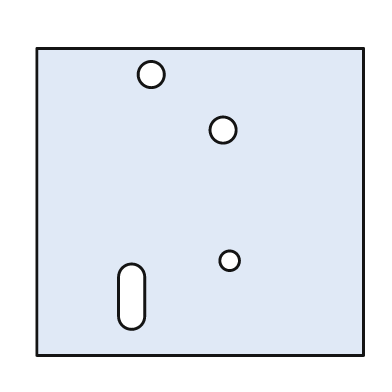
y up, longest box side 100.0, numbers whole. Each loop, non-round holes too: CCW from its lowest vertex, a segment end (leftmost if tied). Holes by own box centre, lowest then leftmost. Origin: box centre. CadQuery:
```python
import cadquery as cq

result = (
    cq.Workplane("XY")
    .moveTo(-50.0, -47.0)
    .lineTo(50.0, -47.0)
    .lineTo(50.0, 47.0)
    .lineTo(-50.0, 47.0)
    .close()
    .moveTo(-25.0, -35.0)
    .threePointArc((-21.0, -39.0), (-17.0, -35.0))
    .lineTo(-17.0, -23.0)
    .threePointArc((-21.0, -19.0), (-25.0, -23.0))
    .close()
    .moveTo(9.0, -18.0)
    .circle(3.0)
    .moveTo(7.0, 22.0)
    .circle(4.0)
    .moveTo(-15.0, 39.0)
    .circle(4.0)
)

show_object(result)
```